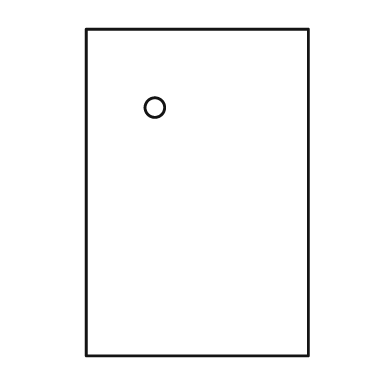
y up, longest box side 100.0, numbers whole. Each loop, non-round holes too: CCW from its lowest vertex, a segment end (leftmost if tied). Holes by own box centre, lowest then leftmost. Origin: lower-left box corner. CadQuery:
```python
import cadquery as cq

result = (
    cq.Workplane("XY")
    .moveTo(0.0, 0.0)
    .lineTo(68.0, 0.0)
    .lineTo(68.0, 100.0)
    .lineTo(0.0, 100.0)
    .close()
    .moveTo(21.0, 76.0)
    .circle(3.0)
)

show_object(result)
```